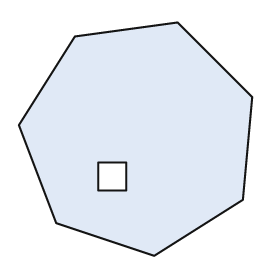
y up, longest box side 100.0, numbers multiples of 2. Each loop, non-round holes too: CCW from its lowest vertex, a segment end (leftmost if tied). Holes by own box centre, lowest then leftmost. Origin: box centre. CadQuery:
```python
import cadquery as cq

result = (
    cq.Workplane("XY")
    .moveTo(8.0, -50.0)
    .lineTo(46.0, -26.0)
    .lineTo(50.0, 18.0)
    .lineTo(18.0, 50.0)
    .lineTo(-26.0, 44.0)
    .lineTo(-50.0, 6.0)
    .lineTo(-34.0, -36.0)
    .close()
    .moveTo(-16.0, -22.0)
    .lineTo(-4.0, -22.0)
    .lineTo(-4.0, -10.0)
    .lineTo(-16.0, -10.0)
    .close()
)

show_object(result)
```